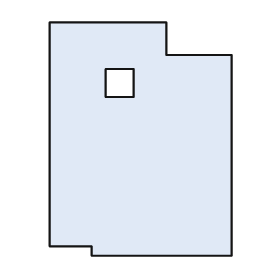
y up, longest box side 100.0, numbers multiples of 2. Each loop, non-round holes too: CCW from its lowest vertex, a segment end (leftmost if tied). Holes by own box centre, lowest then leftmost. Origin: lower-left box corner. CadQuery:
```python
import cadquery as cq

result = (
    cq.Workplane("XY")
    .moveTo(18.0, 0.0)
    .lineTo(78.0, 0.0)
    .lineTo(78.0, 86.0)
    .lineTo(50.0, 86.0)
    .lineTo(50.0, 100.0)
    .lineTo(0.0, 100.0)
    .lineTo(0.0, 4.0)
    .lineTo(18.0, 4.0)
    .close()
    .moveTo(24.0, 68.0)
    .lineTo(36.0, 68.0)
    .lineTo(36.0, 80.0)
    .lineTo(24.0, 80.0)
    .close()
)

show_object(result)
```